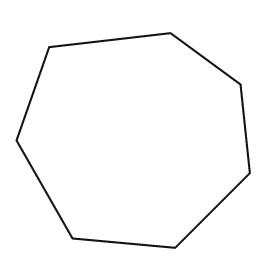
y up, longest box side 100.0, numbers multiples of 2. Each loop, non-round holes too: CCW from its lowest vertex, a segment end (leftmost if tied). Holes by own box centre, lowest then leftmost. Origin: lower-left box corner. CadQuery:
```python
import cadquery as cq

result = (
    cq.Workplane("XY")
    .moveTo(68.0, 0.0)
    .lineTo(100.0, 32.0)
    .lineTo(96.0, 70.0)
    .lineTo(66.0, 92.0)
    .lineTo(14.0, 86.0)
    .lineTo(0.0, 46.0)
    .lineTo(24.0, 4.0)
    .close()
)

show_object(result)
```